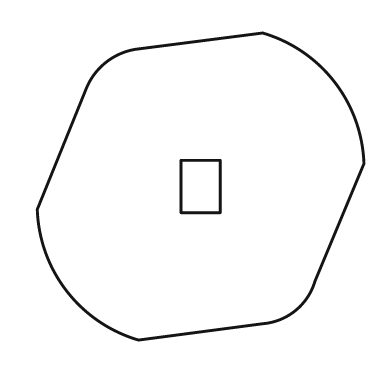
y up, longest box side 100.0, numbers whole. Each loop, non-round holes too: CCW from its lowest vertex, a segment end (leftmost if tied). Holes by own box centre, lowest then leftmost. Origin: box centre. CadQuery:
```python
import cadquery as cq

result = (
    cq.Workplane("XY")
    .moveTo(-19.0, -47.0)
    .lineTo(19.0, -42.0)
    .threePointArc((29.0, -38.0), (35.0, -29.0))
    .lineTo(50.0, 7.0)
    .threePointArc((41.0, 32.0), (19.0, 47.0))
    .lineTo(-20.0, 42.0)
    .threePointArc((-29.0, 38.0), (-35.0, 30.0))
    .lineTo(-50.0, -7.0)
    .threePointArc((-41.0, -32.0), (-19.0, -47.0))
    .close()
    .moveTo(-6.0, -8.0)
    .lineTo(6.0, -8.0)
    .lineTo(6.0, 8.0)
    .lineTo(-6.0, 8.0)
    .close()
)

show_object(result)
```